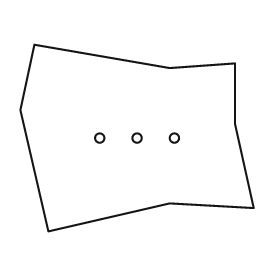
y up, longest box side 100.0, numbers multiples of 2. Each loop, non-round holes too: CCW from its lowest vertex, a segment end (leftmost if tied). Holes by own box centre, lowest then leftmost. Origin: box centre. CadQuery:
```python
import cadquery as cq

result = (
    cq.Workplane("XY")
    .moveTo(-38.0, -40.0)
    .lineTo(14.0, -28.0)
    .lineTo(50.0, -30.0)
    .lineTo(42.0, 6.0)
    .lineTo(42.0, 32.0)
    .lineTo(14.0, 30.0)
    .lineTo(-44.0, 40.0)
    .lineTo(-50.0, 12.0)
    .close()
    .moveTo(-16.0, 0.0)
    .circle(2.0)
    .moveTo(0.0, 0.0)
    .circle(2.0)
    .moveTo(16.0, 0.0)
    .circle(2.0)
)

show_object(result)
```